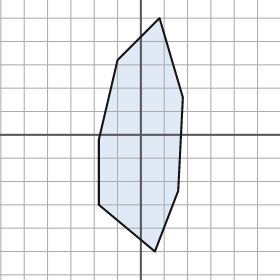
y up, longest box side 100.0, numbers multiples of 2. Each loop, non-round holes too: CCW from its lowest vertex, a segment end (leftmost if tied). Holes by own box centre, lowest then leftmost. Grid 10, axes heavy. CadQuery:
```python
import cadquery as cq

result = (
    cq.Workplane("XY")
    .moveTo(6.0, -50.0)
    .lineTo(16.0, -24.0)
    .lineTo(18.0, 16.0)
    .lineTo(8.0, 50.0)
    .lineTo(-10.0, 32.0)
    .lineTo(-18.0, -2.0)
    .lineTo(-18.0, -30.0)
    .close()
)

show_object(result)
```